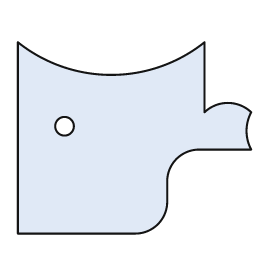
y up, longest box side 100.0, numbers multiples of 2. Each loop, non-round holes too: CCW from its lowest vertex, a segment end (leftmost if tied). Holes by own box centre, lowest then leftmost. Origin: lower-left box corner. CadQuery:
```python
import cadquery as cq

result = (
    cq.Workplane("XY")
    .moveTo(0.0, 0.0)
    .lineTo(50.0, 0.0)
    .threePointArc((60.0, 4.0), (64.0, 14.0))
    .lineTo(64.0, 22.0)
    .threePointArc((68.0, 32.0), (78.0, 36.0))
    .lineTo(100.0, 36.0)
    .threePointArc((98.0, 44.0), (100.0, 52.0))
    .threePointArc((90.0, 56.0), (80.0, 52.0))
    .lineTo(80.0, 82.0)
    .threePointArc((40.0, 68.0), (0.0, 82.0))
    .close()
    .moveTo(20.0, 46.0)
    .circle(4.0)
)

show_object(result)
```